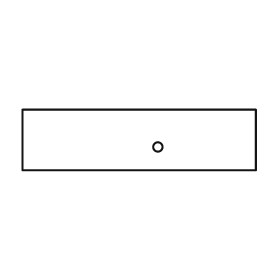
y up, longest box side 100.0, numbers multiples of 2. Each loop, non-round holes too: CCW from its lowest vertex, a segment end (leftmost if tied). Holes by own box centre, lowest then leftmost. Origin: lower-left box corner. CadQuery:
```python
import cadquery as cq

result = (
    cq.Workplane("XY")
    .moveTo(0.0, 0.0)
    .lineTo(100.0, 0.0)
    .lineTo(100.0, 26.0)
    .lineTo(0.0, 26.0)
    .close()
    .moveTo(58.0, 10.0)
    .circle(2.0)
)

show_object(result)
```